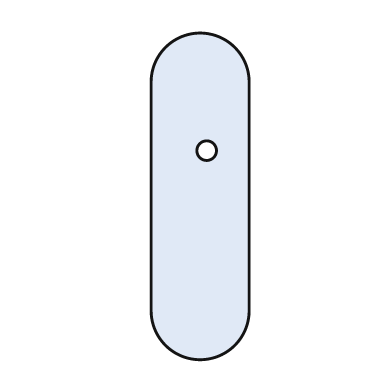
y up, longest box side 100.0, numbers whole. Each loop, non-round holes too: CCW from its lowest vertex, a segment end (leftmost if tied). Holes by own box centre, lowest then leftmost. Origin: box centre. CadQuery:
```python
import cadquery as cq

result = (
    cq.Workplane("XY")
    .moveTo(-15.0, -35.0)
    .threePointArc((0.0, -50.0), (15.0, -35.0))
    .lineTo(15.0, 35.0)
    .threePointArc((0.0, 50.0), (-15.0, 35.0))
    .close()
    .moveTo(2.0, 14.0)
    .circle(3.0)
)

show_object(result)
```